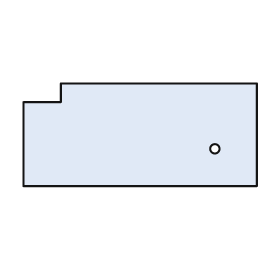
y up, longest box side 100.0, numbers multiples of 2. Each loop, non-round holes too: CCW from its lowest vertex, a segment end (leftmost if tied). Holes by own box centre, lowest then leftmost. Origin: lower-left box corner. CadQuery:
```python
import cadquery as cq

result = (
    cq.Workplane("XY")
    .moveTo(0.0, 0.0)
    .lineTo(100.0, 0.0)
    .lineTo(100.0, 44.0)
    .lineTo(16.0, 44.0)
    .lineTo(16.0, 36.0)
    .lineTo(0.0, 36.0)
    .close()
    .moveTo(82.0, 16.0)
    .circle(2.0)
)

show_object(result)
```